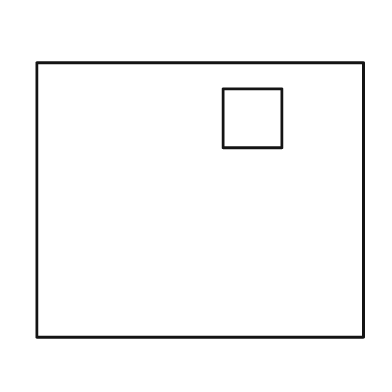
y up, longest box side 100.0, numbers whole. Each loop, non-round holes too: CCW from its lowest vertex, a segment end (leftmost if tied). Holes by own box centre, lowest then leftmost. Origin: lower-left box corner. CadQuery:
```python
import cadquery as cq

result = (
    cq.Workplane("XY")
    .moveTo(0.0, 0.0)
    .lineTo(100.0, 0.0)
    .lineTo(100.0, 84.0)
    .lineTo(0.0, 84.0)
    .close()
    .moveTo(57.0, 58.0)
    .lineTo(75.0, 58.0)
    .lineTo(75.0, 76.0)
    .lineTo(57.0, 76.0)
    .close()
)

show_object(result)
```